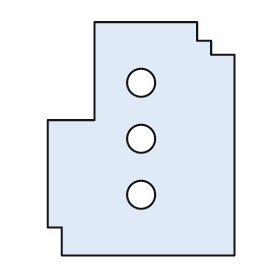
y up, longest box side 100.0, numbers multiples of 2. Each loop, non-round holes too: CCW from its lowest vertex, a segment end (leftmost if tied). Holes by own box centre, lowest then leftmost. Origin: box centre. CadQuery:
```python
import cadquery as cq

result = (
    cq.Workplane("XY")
    .moveTo(-34.0, -50.0)
    .lineTo(40.0, -50.0)
    .lineTo(40.0, 36.0)
    .lineTo(30.0, 36.0)
    .lineTo(30.0, 42.0)
    .lineTo(24.0, 42.0)
    .lineTo(24.0, 50.0)
    .lineTo(-20.0, 50.0)
    .lineTo(-20.0, 8.0)
    .lineTo(-40.0, 8.0)
    .lineTo(-40.0, -38.0)
    .lineTo(-34.0, -38.0)
    .close()
    .moveTo(0.0, -24.0)
    .circle(6.0)
    .moveTo(0.0, 0.0)
    .circle(6.0)
    .moveTo(0.0, 24.0)
    .circle(6.0)
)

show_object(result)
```